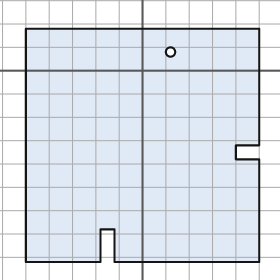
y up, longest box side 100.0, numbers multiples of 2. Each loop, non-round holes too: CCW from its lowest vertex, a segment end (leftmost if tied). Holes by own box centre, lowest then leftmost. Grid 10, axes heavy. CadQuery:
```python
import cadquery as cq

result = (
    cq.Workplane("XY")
    .moveTo(-50.0, -82.0)
    .lineTo(-18.0, -82.0)
    .lineTo(-18.0, -68.0)
    .lineTo(-12.0, -68.0)
    .lineTo(-12.0, -82.0)
    .lineTo(50.0, -82.0)
    .lineTo(50.0, -38.0)
    .lineTo(40.0, -38.0)
    .lineTo(40.0, -32.0)
    .lineTo(50.0, -32.0)
    .lineTo(50.0, 18.0)
    .lineTo(-50.0, 18.0)
    .close()
    .moveTo(12.0, 8.0)
    .circle(2.0)
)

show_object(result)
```